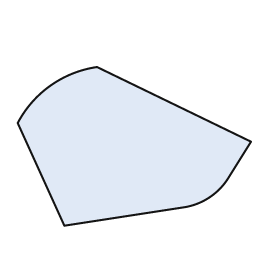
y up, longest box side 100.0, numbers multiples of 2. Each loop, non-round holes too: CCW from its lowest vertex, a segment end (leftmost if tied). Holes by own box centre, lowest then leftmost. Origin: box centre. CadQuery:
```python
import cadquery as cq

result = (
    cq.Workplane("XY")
    .moveTo(-30.0, -34.0)
    .lineTo(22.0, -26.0)
    .threePointArc((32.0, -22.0), (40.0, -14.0))
    .lineTo(50.0, 2.0)
    .lineTo(-16.0, 34.0)
    .threePointArc((-36.0, 26.0), (-50.0, 10.0))
    .close()
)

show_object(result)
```